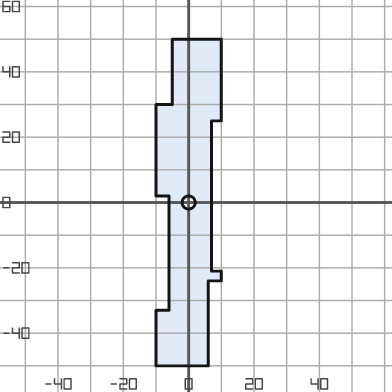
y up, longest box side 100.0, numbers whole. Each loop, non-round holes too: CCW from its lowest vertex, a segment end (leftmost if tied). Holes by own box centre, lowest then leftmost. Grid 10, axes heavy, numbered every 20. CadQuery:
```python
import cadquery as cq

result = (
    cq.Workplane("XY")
    .moveTo(-10.0, -50.0)
    .lineTo(6.0, -50.0)
    .lineTo(6.0, -24.0)
    .lineTo(10.0, -24.0)
    .lineTo(10.0, -21.0)
    .lineTo(7.0, -21.0)
    .lineTo(7.0, 25.0)
    .lineTo(10.0, 25.0)
    .lineTo(10.0, 50.0)
    .lineTo(-5.0, 50.0)
    .lineTo(-5.0, 30.0)
    .lineTo(-10.0, 30.0)
    .lineTo(-10.0, 2.0)
    .lineTo(-6.0, 2.0)
    .lineTo(-6.0, -33.0)
    .lineTo(-10.0, -33.0)
    .close()
    .moveTo(0.0, 0.0)
    .circle(2.0)
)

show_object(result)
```